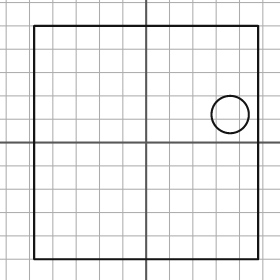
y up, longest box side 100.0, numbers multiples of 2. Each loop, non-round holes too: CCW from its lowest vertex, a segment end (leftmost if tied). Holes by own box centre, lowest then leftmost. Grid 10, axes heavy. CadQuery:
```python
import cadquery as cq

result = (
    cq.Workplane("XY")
    .moveTo(-48.0, -50.0)
    .lineTo(48.0, -50.0)
    .lineTo(48.0, 50.0)
    .lineTo(-48.0, 50.0)
    .close()
    .moveTo(36.0, 12.0)
    .circle(8.0)
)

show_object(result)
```